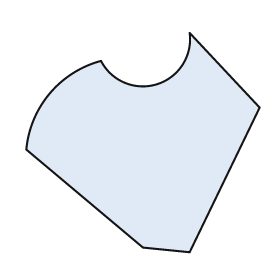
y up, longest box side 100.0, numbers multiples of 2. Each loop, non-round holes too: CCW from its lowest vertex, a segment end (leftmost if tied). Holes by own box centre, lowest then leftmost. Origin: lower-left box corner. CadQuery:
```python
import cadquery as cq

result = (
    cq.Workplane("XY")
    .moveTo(70.0, 0.0)
    .lineTo(100.0, 62.0)
    .lineTo(70.0, 94.0)
    .threePointArc((56.0, 72.0), (32.0, 82.0))
    .threePointArc((10.0, 68.0), (0.0, 44.0))
    .lineTo(50.0, 2.0)
    .close()
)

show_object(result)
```